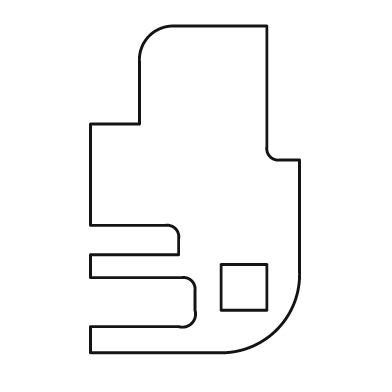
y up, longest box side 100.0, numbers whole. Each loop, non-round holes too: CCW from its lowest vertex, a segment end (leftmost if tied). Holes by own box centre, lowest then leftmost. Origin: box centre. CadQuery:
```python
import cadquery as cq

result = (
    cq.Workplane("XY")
    .moveTo(-32.0, -50.0)
    .lineTo(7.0, -50.0)
    .threePointArc((25.0, -43.0), (32.0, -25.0))
    .lineTo(32.0, 9.0)
    .lineTo(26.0, 9.0)
    .threePointArc((23.0, 10.0), (22.0, 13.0))
    .lineTo(22.0, 50.0)
    .lineTo(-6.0, 50.0)
    .threePointArc((-14.0, 47.0), (-17.0, 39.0))
    .lineTo(-17.0, 20.0)
    .lineTo(-32.0, 20.0)
    .lineTo(-32.0, -11.0)
    .lineTo(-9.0, -11.0)
    .threePointArc((-6.0, -12.0), (-5.0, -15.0))
    .lineTo(-5.0, -20.0)
    .lineTo(-32.0, -20.0)
    .lineTo(-32.0, -27.0)
    .lineTo(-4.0, -27.0)
    .threePointArc((-1.0, -28.0), (0.0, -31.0))
    .lineTo(0.0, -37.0)
    .threePointArc((-1.0, -41.0), (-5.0, -42.0))
    .lineTo(-32.0, -42.0)
    .close()
    .moveTo(8.0, -37.0)
    .lineTo(22.0, -37.0)
    .lineTo(22.0, -23.0)
    .lineTo(8.0, -23.0)
    .close()
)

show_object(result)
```